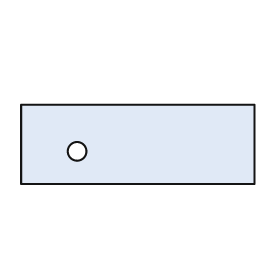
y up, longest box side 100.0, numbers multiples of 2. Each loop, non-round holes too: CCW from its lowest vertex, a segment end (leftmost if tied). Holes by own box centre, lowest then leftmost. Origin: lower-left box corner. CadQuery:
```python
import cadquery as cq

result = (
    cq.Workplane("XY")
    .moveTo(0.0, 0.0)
    .lineTo(100.0, 0.0)
    .lineTo(100.0, 34.0)
    .lineTo(0.0, 34.0)
    .close()
    .moveTo(24.0, 14.0)
    .circle(4.0)
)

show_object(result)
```